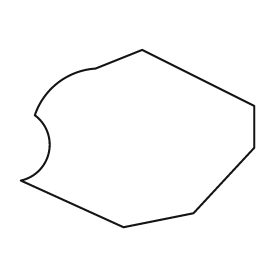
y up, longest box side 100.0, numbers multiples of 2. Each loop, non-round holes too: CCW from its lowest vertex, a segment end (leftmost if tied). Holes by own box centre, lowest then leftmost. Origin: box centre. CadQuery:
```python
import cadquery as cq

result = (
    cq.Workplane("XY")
    .moveTo(-6.0, -38.0)
    .lineTo(24.0, -32.0)
    .lineTo(50.0, -4.0)
    .lineTo(50.0, 14.0)
    .lineTo(2.0, 38.0)
    .lineTo(-18.0, 30.0)
    .threePointArc((-34.0, 24.0), (-44.0, 10.0))
    .threePointArc((-38.0, -6.0), (-50.0, -18.0))
    .close()
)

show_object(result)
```